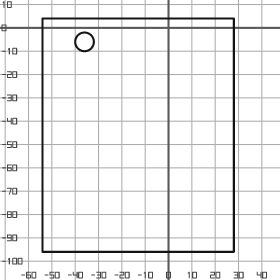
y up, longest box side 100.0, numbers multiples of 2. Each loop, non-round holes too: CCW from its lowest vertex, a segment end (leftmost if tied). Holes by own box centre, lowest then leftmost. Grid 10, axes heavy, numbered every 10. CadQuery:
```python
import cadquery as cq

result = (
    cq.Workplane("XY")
    .moveTo(-54.0, -96.0)
    .lineTo(28.0, -96.0)
    .lineTo(28.0, 4.0)
    .lineTo(-54.0, 4.0)
    .close()
    .moveTo(-36.0, -6.0)
    .circle(4.0)
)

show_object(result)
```